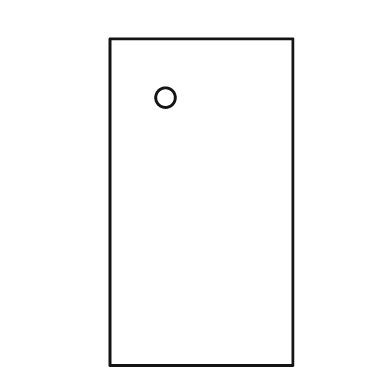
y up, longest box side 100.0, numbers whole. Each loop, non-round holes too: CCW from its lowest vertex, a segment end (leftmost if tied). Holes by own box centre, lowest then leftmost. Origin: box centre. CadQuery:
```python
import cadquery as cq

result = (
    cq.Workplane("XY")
    .moveTo(-28.0, -50.0)
    .lineTo(28.0, -50.0)
    .lineTo(28.0, 50.0)
    .lineTo(-28.0, 50.0)
    .close()
    .moveTo(-11.0, 32.0)
    .circle(3.0)
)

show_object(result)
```